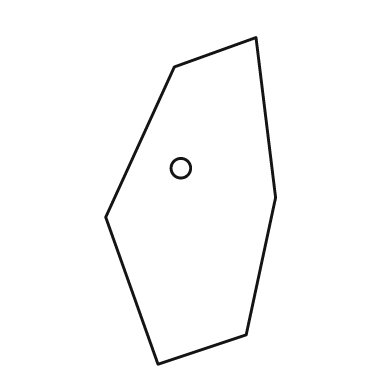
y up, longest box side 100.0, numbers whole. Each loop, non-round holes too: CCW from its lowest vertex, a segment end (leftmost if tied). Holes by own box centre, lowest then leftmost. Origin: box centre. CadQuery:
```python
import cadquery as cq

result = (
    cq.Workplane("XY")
    .moveTo(-10.0, -50.0)
    .lineTo(17.0, -41.0)
    .lineTo(26.0, 1.0)
    .lineTo(20.0, 50.0)
    .lineTo(-5.0, 41.0)
    .lineTo(-26.0, -5.0)
    .close()
    .moveTo(-3.0, 10.0)
    .circle(3.0)
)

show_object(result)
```